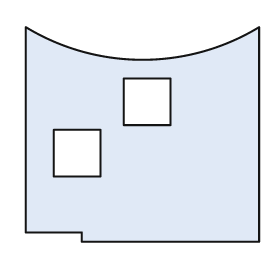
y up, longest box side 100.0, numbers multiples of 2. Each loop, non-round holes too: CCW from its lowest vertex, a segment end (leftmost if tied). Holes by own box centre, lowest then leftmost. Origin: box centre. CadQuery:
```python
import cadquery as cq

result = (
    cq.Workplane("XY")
    .moveTo(-26.0, -46.0)
    .lineTo(50.0, -46.0)
    .lineTo(50.0, 46.0)
    .threePointArc((0.0, 32.0), (-50.0, 46.0))
    .lineTo(-50.0, -42.0)
    .lineTo(-26.0, -42.0)
    .close()
    .moveTo(-38.0, -18.0)
    .lineTo(-18.0, -18.0)
    .lineTo(-18.0, 2.0)
    .lineTo(-38.0, 2.0)
    .close()
    .moveTo(-8.0, 4.0)
    .lineTo(12.0, 4.0)
    .lineTo(12.0, 24.0)
    .lineTo(-8.0, 24.0)
    .close()
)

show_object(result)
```